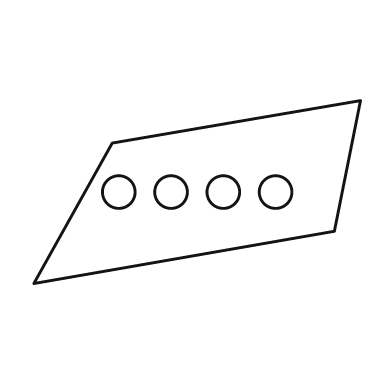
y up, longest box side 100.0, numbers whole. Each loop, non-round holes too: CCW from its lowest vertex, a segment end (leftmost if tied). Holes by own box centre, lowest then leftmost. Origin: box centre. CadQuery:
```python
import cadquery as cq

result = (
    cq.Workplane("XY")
    .moveTo(-50.0, -28.0)
    .lineTo(42.0, -12.0)
    .lineTo(50.0, 28.0)
    .lineTo(-26.0, 15.0)
    .close()
    .moveTo(-24.0, 0.0)
    .circle(5.0)
    .moveTo(-8.0, 0.0)
    .circle(5.0)
    .moveTo(8.0, 0.0)
    .circle(5.0)
    .moveTo(24.0, 0.0)
    .circle(5.0)
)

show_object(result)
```